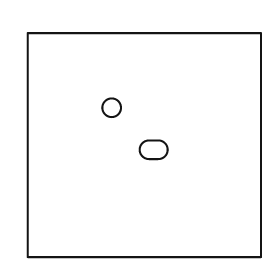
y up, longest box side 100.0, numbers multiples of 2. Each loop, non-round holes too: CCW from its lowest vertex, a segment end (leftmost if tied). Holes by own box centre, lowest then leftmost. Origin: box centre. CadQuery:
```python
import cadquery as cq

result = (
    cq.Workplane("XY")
    .moveTo(-50.0, -48.0)
    .lineTo(50.0, -48.0)
    .lineTo(50.0, 48.0)
    .lineTo(-50.0, 48.0)
    .close()
    .moveTo(2.0, -6.0)
    .lineTo(6.0, -6.0)
    .threePointArc((10.0, -2.0), (6.0, 2.0))
    .lineTo(2.0, 2.0)
    .threePointArc((-2.0, -2.0), (2.0, -6.0))
    .close()
    .moveTo(-14.0, 16.0)
    .circle(4.0)
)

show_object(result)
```